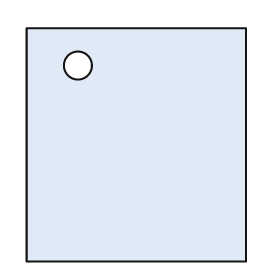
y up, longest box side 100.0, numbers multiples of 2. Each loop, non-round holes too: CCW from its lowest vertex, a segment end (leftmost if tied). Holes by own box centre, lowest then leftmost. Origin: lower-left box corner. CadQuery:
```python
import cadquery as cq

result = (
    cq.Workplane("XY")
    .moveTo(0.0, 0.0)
    .lineTo(94.0, 0.0)
    .lineTo(94.0, 100.0)
    .lineTo(0.0, 100.0)
    .close()
    .moveTo(22.0, 84.0)
    .circle(6.0)
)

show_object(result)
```